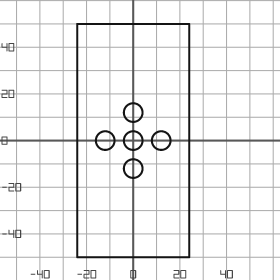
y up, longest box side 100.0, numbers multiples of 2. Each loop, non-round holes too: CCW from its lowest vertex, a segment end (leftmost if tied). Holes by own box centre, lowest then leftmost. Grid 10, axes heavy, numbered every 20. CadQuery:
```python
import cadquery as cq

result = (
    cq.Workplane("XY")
    .moveTo(-24.0, -50.0)
    .lineTo(24.0, -50.0)
    .lineTo(24.0, 50.0)
    .lineTo(-24.0, 50.0)
    .close()
    .moveTo(0.0, -12.0)
    .circle(4.0)
    .moveTo(-12.0, 0.0)
    .circle(4.0)
    .moveTo(0.0, 0.0)
    .circle(4.0)
    .moveTo(12.0, 0.0)
    .circle(4.0)
    .moveTo(0.0, 12.0)
    .circle(4.0)
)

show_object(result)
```